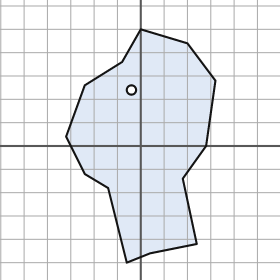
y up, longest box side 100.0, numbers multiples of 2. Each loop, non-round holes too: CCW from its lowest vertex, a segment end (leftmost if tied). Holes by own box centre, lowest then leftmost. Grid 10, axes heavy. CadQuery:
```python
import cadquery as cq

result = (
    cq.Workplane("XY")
    .moveTo(-6.0, -50.0)
    .lineTo(4.0, -46.0)
    .lineTo(24.0, -42.0)
    .lineTo(18.0, -14.0)
    .lineTo(28.0, 0.0)
    .lineTo(32.0, 28.0)
    .lineTo(20.0, 44.0)
    .lineTo(0.0, 50.0)
    .lineTo(-8.0, 36.0)
    .lineTo(-24.0, 26.0)
    .lineTo(-32.0, 4.0)
    .lineTo(-24.0, -12.0)
    .lineTo(-14.0, -18.0)
    .close()
    .moveTo(-4.0, 24.0)
    .circle(2.0)
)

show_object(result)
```